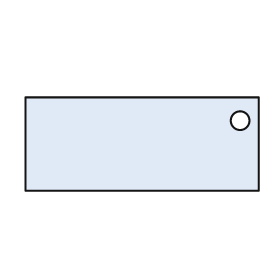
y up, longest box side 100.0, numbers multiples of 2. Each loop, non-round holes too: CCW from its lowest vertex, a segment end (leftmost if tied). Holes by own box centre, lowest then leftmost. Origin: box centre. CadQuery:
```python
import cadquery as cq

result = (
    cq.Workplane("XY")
    .moveTo(-50.0, -20.0)
    .lineTo(50.0, -20.0)
    .lineTo(50.0, 20.0)
    .lineTo(-50.0, 20.0)
    .close()
    .moveTo(42.0, 10.0)
    .circle(4.0)
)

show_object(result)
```